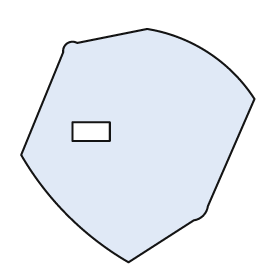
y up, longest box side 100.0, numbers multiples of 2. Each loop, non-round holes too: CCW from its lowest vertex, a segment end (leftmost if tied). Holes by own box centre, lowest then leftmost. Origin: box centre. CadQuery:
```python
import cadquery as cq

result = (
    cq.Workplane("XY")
    .moveTo(-4.0, -50.0)
    .lineTo(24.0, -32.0)
    .threePointArc((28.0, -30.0), (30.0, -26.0))
    .lineTo(50.0, 20.0)
    .threePointArc((30.0, 40.0), (4.0, 50.0))
    .lineTo(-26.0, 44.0)
    .threePointArc((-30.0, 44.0), (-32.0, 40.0))
    .lineTo(-50.0, -4.0)
    .threePointArc((-30.0, -30.0), (-4.0, -50.0))
    .close()
    .moveTo(-28.0, 2.0)
    .lineTo(-12.0, 2.0)
    .lineTo(-12.0, 10.0)
    .lineTo(-28.0, 10.0)
    .close()
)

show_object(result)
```